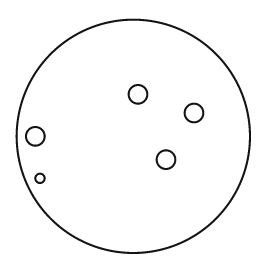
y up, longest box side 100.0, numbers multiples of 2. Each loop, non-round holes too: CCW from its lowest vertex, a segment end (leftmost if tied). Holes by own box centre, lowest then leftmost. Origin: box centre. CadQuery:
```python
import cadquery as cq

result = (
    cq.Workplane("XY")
    .moveTo(0.0, 0.0)
    .circle(50.0)
    .moveTo(-40.0, -18.0)
    .circle(2.0)
    .moveTo(14.0, -10.0)
    .circle(4.0)
    .moveTo(-42.0, 0.0)
    .circle(4.0)
    .moveTo(26.0, 10.0)
    .circle(4.0)
    .moveTo(2.0, 18.0)
    .circle(4.0)
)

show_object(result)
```